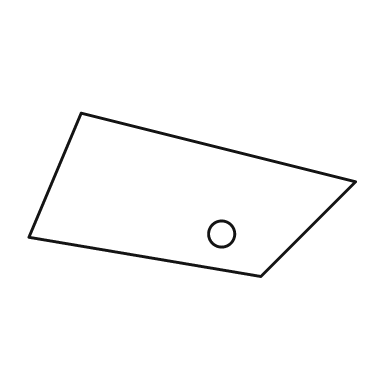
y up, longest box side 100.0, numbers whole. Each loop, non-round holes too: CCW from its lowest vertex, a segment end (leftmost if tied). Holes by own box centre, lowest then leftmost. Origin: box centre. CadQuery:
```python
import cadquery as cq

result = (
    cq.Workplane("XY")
    .moveTo(21.0, -25.0)
    .lineTo(50.0, 4.0)
    .lineTo(-34.0, 25.0)
    .lineTo(-50.0, -13.0)
    .close()
    .moveTo(9.0, -12.0)
    .circle(4.0)
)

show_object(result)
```